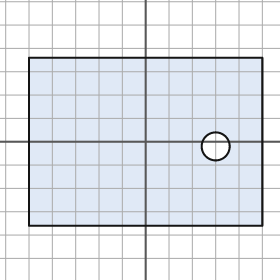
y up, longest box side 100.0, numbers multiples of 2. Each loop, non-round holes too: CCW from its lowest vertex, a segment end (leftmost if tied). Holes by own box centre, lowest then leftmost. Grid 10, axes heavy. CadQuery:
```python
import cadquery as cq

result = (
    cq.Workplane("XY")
    .moveTo(-50.0, -36.0)
    .lineTo(50.0, -36.0)
    .lineTo(50.0, 36.0)
    .lineTo(-50.0, 36.0)
    .close()
    .moveTo(30.0, -2.0)
    .circle(6.0)
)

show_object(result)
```